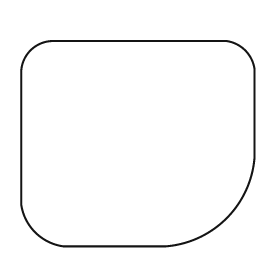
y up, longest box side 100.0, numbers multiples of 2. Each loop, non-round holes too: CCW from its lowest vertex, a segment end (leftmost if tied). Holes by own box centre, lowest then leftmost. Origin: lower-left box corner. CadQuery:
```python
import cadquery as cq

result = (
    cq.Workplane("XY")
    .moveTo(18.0, 0.0)
    .lineTo(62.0, 0.0)
    .threePointArc((88.0, 12.0), (100.0, 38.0))
    .lineTo(100.0, 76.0)
    .threePointArc((96.0, 84.0), (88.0, 88.0))
    .lineTo(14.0, 88.0)
    .threePointArc((4.0, 84.0), (0.0, 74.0))
    .lineTo(0.0, 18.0)
    .threePointArc((6.0, 6.0), (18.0, 0.0))
    .close()
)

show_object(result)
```